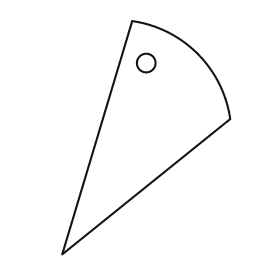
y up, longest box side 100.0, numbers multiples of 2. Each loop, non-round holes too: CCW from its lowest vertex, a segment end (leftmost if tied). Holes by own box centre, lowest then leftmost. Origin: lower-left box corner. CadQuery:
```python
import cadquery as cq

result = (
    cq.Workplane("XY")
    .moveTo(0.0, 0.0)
    .lineTo(72.0, 58.0)
    .threePointArc((58.0, 86.0), (30.0, 100.0))
    .close()
    .moveTo(36.0, 82.0)
    .circle(4.0)
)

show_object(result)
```